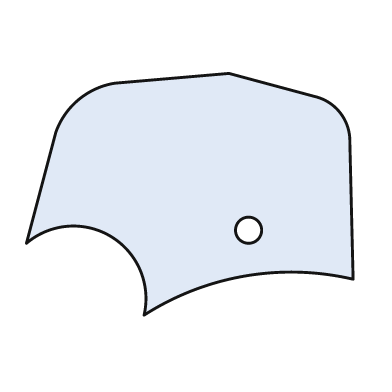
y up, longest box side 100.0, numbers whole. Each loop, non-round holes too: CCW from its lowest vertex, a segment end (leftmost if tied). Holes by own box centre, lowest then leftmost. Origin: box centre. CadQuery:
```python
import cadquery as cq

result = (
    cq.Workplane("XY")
    .moveTo(-14.0, -37.0)
    .threePointArc((17.0, -25.0), (50.0, -26.0))
    .lineTo(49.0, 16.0)
    .threePointArc((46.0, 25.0), (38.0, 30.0))
    .lineTo(12.0, 37.0)
    .lineTo(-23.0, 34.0)
    .threePointArc((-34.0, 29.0), (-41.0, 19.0))
    .lineTo(-50.0, -15.0)
    .threePointArc((-24.0, -13.0), (-14.0, -37.0))
    .close()
    .moveTo(18.0, -11.0)
    .circle(4.0)
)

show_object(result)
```